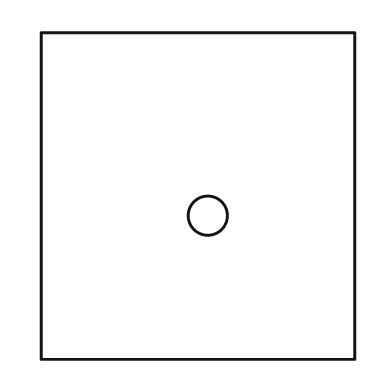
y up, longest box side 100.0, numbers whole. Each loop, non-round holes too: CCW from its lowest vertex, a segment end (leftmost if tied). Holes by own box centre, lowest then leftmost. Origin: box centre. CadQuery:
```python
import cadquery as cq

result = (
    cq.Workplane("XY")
    .moveTo(-48.0, -50.0)
    .lineTo(48.0, -50.0)
    .lineTo(48.0, 50.0)
    .lineTo(-48.0, 50.0)
    .close()
    .moveTo(3.0, -6.0)
    .circle(6.0)
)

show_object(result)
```